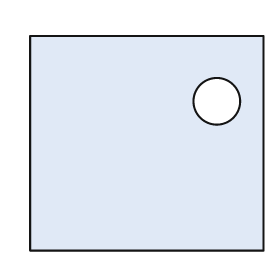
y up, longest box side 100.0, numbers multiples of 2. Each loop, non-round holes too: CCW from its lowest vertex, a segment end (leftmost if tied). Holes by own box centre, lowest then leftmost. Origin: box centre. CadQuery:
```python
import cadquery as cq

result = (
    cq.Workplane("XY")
    .moveTo(-50.0, -46.0)
    .lineTo(50.0, -46.0)
    .lineTo(50.0, 46.0)
    .lineTo(-50.0, 46.0)
    .close()
    .moveTo(30.0, 18.0)
    .circle(10.0)
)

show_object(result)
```